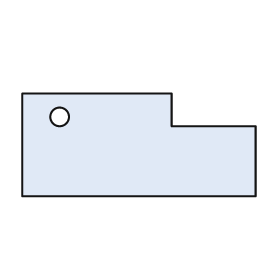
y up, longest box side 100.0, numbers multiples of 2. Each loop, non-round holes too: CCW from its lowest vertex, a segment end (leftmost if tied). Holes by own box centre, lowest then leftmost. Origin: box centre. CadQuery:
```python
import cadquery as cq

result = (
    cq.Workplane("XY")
    .moveTo(-50.0, -22.0)
    .lineTo(50.0, -22.0)
    .lineTo(50.0, 8.0)
    .lineTo(14.0, 8.0)
    .lineTo(14.0, 22.0)
    .lineTo(-50.0, 22.0)
    .close()
    .moveTo(-34.0, 12.0)
    .circle(4.0)
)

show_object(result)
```